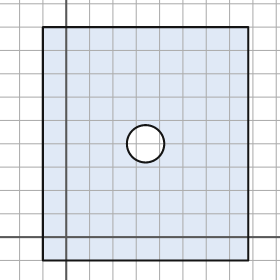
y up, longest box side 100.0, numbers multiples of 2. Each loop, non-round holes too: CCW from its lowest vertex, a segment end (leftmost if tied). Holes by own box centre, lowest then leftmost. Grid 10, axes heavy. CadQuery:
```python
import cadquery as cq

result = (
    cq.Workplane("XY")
    .moveTo(-10.0, -10.0)
    .lineTo(78.0, -10.0)
    .lineTo(78.0, 90.0)
    .lineTo(-10.0, 90.0)
    .close()
    .moveTo(34.0, 40.0)
    .circle(8.0)
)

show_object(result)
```